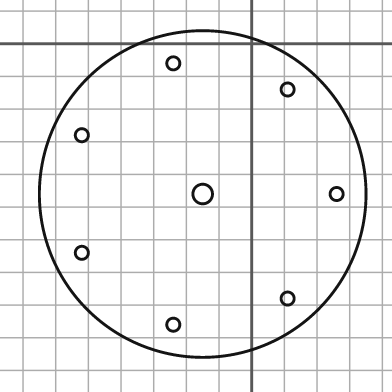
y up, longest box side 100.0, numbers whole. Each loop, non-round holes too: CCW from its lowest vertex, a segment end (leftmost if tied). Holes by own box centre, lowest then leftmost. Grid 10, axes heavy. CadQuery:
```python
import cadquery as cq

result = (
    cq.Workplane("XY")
    .moveTo(-15.0, -46.0)
    .circle(50.0)
    .moveTo(-24.0, -86.0)
    .circle(2.0)
    .moveTo(11.0, -78.0)
    .circle(2.0)
    .moveTo(-52.0, -64.0)
    .circle(2.0)
    .moveTo(-15.0, -46.0)
    .circle(3.0)
    .moveTo(26.0, -46.0)
    .circle(2.0)
    .moveTo(-52.0, -28.0)
    .circle(2.0)
    .moveTo(11.0, -14.0)
    .circle(2.0)
    .moveTo(-24.0, -6.0)
    .circle(2.0)
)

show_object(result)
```